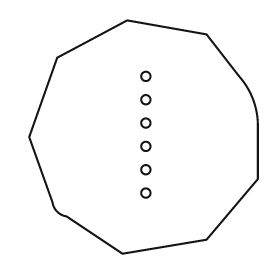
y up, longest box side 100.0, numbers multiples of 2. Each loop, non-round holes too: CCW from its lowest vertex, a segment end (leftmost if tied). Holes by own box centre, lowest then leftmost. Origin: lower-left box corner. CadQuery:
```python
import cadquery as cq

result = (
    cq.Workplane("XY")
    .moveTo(40.0, 0.0)
    .lineTo(76.0, 6.0)
    .lineTo(98.0, 32.0)
    .lineTo(98.0, 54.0)
    .threePointArc((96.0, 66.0), (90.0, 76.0))
    .lineTo(76.0, 94.0)
    .lineTo(42.0, 100.0)
    .lineTo(12.0, 84.0)
    .lineTo(0.0, 50.0)
    .lineTo(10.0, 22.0)
    .threePointArc((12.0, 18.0), (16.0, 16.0))
    .close()
    .moveTo(50.0, 26.0)
    .circle(2.0)
    .moveTo(50.0, 36.0)
    .circle(2.0)
    .moveTo(50.0, 46.0)
    .circle(2.0)
    .moveTo(50.0, 56.0)
    .circle(2.0)
    .moveTo(50.0, 66.0)
    .circle(2.0)
    .moveTo(50.0, 76.0)
    .circle(2.0)
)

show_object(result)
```